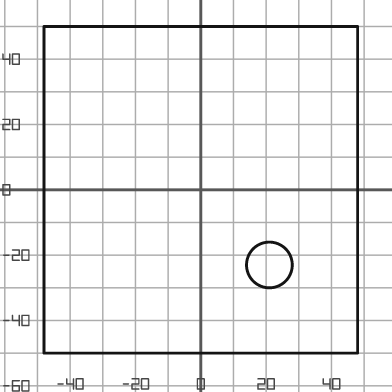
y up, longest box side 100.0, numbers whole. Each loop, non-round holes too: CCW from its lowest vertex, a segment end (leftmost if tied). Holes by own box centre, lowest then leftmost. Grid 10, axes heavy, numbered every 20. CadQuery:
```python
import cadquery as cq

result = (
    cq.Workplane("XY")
    .moveTo(-48.0, -50.0)
    .lineTo(48.0, -50.0)
    .lineTo(48.0, 50.0)
    .lineTo(-48.0, 50.0)
    .close()
    .moveTo(21.0, -23.0)
    .circle(7.0)
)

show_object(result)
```